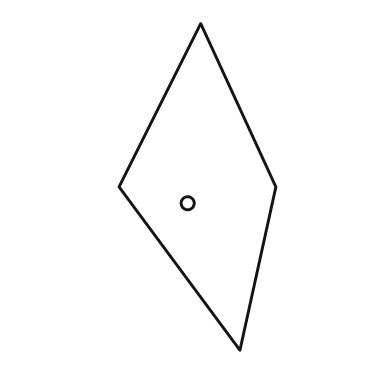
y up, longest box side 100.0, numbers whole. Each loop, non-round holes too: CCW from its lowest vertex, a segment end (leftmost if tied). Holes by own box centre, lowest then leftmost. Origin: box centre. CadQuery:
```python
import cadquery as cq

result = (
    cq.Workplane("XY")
    .moveTo(13.0, -50.0)
    .lineTo(24.0, 0.0)
    .lineTo(1.0, 50.0)
    .lineTo(-24.0, 0.0)
    .close()
    .moveTo(-3.0, -5.0)
    .circle(2.0)
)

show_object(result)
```